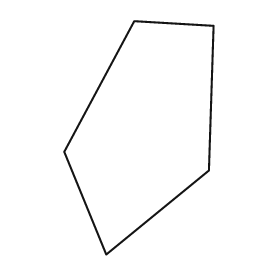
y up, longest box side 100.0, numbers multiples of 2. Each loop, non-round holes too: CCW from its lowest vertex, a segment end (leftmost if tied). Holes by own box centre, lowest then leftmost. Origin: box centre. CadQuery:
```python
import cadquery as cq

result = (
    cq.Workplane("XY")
    .moveTo(-14.0, -50.0)
    .lineTo(30.0, -14.0)
    .lineTo(32.0, 48.0)
    .lineTo(-2.0, 50.0)
    .lineTo(-32.0, -6.0)
    .close()
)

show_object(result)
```